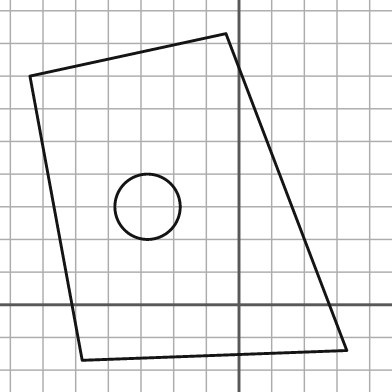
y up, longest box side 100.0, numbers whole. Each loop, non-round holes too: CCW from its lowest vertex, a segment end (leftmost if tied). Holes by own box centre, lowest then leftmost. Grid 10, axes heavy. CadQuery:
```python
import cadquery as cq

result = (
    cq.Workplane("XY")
    .moveTo(-48.0, -17.0)
    .lineTo(33.0, -14.0)
    .lineTo(-4.0, 83.0)
    .lineTo(-64.0, 70.0)
    .close()
    .moveTo(-28.0, 30.0)
    .circle(10.0)
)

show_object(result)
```